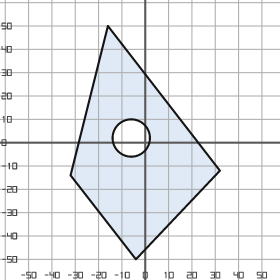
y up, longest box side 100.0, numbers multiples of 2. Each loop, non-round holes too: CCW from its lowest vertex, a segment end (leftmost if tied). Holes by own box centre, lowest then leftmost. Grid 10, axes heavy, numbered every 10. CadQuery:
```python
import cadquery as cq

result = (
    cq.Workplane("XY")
    .moveTo(-4.0, -50.0)
    .lineTo(32.0, -12.0)
    .lineTo(-16.0, 50.0)
    .lineTo(-32.0, -14.0)
    .close()
    .moveTo(-6.0, 2.0)
    .circle(8.0)
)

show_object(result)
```